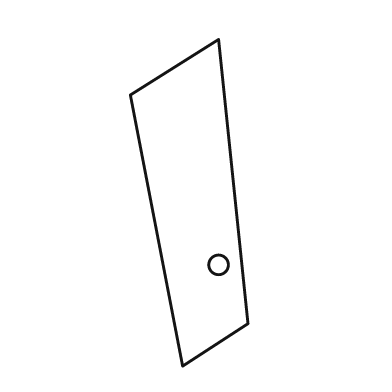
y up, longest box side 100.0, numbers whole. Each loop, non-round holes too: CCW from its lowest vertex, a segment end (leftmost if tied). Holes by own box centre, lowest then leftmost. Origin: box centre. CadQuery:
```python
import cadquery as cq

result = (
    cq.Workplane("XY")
    .moveTo(-2.0, -50.0)
    .lineTo(18.0, -37.0)
    .lineTo(9.0, 50.0)
    .lineTo(-18.0, 33.0)
    .close()
    .moveTo(9.0, -19.0)
    .circle(3.0)
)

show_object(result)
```